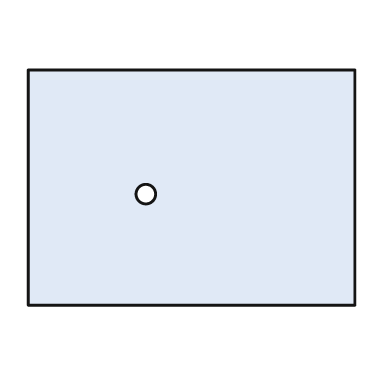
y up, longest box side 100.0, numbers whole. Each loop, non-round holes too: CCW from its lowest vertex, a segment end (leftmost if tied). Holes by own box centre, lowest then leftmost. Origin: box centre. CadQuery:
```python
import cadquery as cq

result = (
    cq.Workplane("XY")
    .moveTo(-50.0, -36.0)
    .lineTo(50.0, -36.0)
    .lineTo(50.0, 36.0)
    .lineTo(-50.0, 36.0)
    .close()
    .moveTo(-14.0, -2.0)
    .circle(3.0)
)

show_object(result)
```